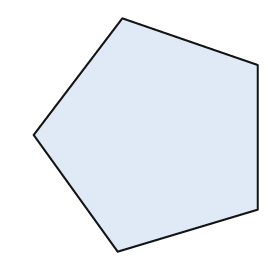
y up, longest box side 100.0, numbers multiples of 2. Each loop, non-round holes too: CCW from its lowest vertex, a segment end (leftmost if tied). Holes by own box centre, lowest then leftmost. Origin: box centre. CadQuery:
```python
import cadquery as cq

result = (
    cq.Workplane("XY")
    .moveTo(-12.0, -50.0)
    .lineTo(48.0, -32.0)
    .lineTo(48.0, 30.0)
    .lineTo(-10.0, 50.0)
    .lineTo(-48.0, 0.0)
    .close()
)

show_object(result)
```